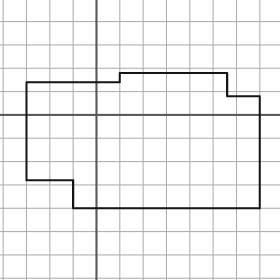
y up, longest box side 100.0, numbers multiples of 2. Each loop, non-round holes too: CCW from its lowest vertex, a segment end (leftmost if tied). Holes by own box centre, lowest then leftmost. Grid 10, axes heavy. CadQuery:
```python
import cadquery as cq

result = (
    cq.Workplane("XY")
    .moveTo(-10.0, -40.0)
    .lineTo(70.0, -40.0)
    .lineTo(70.0, 8.0)
    .lineTo(56.0, 8.0)
    .lineTo(56.0, 18.0)
    .lineTo(10.0, 18.0)
    .lineTo(10.0, 14.0)
    .lineTo(-30.0, 14.0)
    .lineTo(-30.0, -28.0)
    .lineTo(-10.0, -28.0)
    .close()
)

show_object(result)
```